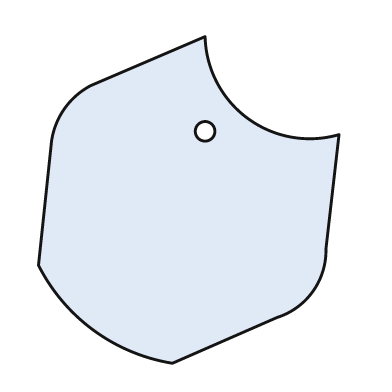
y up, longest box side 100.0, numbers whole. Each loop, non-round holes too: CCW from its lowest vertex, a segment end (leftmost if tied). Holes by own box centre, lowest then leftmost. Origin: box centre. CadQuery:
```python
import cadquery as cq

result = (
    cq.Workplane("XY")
    .moveTo(-5.0, -50.0)
    .lineTo(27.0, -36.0)
    .threePointArc((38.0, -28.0), (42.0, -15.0))
    .lineTo(46.0, 20.0)
    .threePointArc((18.0, 25.0), (5.0, 50.0))
    .lineTo(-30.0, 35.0)
    .threePointArc((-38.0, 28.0), (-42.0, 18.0))
    .lineTo(-46.0, -20.0)
    .threePointArc((-29.0, -40.0), (-5.0, -50.0))
    .close()
    .moveTo(5.0, 21.0)
    .circle(3.0)
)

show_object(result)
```